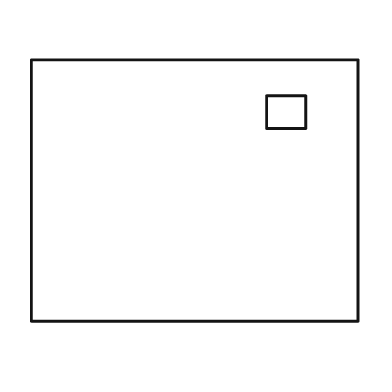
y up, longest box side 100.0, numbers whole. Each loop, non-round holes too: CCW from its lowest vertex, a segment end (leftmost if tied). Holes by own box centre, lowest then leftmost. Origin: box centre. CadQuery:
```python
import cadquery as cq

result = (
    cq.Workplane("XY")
    .moveTo(-50.0, -40.0)
    .lineTo(50.0, -40.0)
    .lineTo(50.0, 40.0)
    .lineTo(-50.0, 40.0)
    .close()
    .moveTo(22.0, 19.0)
    .lineTo(34.0, 19.0)
    .lineTo(34.0, 29.0)
    .lineTo(22.0, 29.0)
    .close()
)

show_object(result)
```